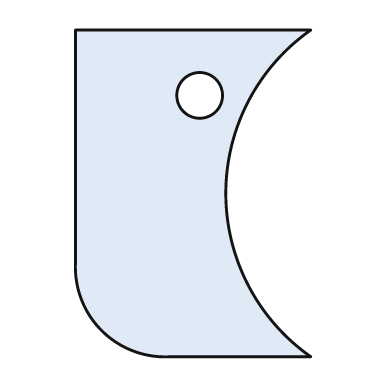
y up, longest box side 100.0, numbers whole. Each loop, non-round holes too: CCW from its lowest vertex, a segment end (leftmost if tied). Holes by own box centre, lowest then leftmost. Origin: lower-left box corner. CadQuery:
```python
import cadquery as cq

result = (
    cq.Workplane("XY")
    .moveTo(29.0, 0.0)
    .lineTo(72.0, 0.0)
    .threePointArc((46.0, 50.0), (72.0, 100.0))
    .lineTo(0.0, 100.0)
    .lineTo(0.0, 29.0)
    .threePointArc((8.0, 8.0), (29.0, 0.0))
    .close()
    .moveTo(38.0, 80.0)
    .circle(7.0)
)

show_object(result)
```